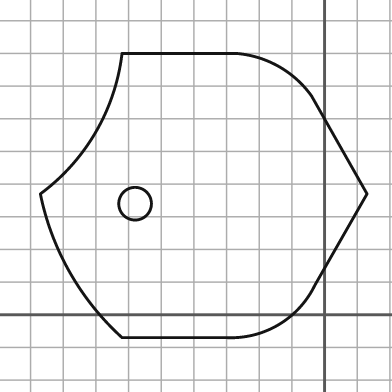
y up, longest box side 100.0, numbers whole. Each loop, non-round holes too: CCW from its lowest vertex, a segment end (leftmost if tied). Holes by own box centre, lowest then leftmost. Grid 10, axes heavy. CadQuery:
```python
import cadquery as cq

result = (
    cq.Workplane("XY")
    .moveTo(-62.0, -7.0)
    .lineTo(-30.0, -7.0)
    .threePointArc((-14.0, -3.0), (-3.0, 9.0))
    .lineTo(13.0, 37.0)
    .lineTo(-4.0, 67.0)
    .threePointArc((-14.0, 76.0), (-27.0, 80.0))
    .lineTo(-62.0, 80.0)
    .threePointArc((-70.0, 56.0), (-87.0, 37.0))
    .threePointArc((-78.0, 13.0), (-62.0, -7.0))
    .close()
    .moveTo(-58.0, 34.0)
    .circle(5.0)
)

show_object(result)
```